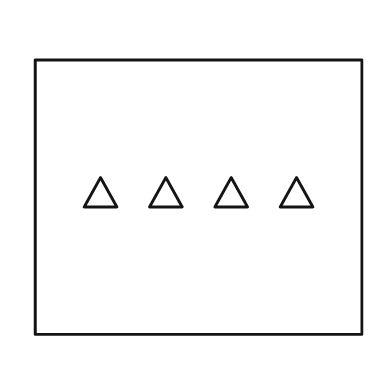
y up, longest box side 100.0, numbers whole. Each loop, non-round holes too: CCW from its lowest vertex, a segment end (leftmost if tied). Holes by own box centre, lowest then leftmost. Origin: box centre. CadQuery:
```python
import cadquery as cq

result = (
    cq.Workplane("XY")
    .moveTo(-50.0, -42.0)
    .lineTo(50.0, -42.0)
    .lineTo(50.0, 42.0)
    .lineTo(-50.0, 42.0)
    .close()
    .moveTo(-35.0, -3.0)
    .lineTo(-25.0, -3.0)
    .lineTo(-30.0, 6.0)
    .close()
    .moveTo(-15.0, -3.0)
    .lineTo(-5.0, -3.0)
    .lineTo(-10.0, 6.0)
    .close()
    .moveTo(5.0, -3.0)
    .lineTo(15.0, -3.0)
    .lineTo(10.0, 6.0)
    .close()
    .moveTo(25.0, -3.0)
    .lineTo(35.0, -3.0)
    .lineTo(30.0, 6.0)
    .close()
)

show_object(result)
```